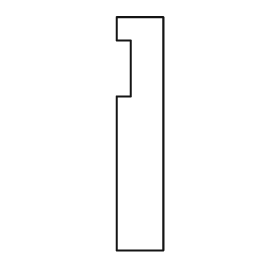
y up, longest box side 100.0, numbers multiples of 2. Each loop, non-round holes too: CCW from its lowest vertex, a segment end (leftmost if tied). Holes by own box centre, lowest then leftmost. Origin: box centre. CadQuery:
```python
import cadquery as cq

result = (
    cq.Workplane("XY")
    .moveTo(-10.0, -50.0)
    .lineTo(10.0, -50.0)
    .lineTo(10.0, 50.0)
    .lineTo(-10.0, 50.0)
    .lineTo(-10.0, 40.0)
    .lineTo(-4.0, 40.0)
    .lineTo(-4.0, 16.0)
    .lineTo(-10.0, 16.0)
    .close()
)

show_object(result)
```